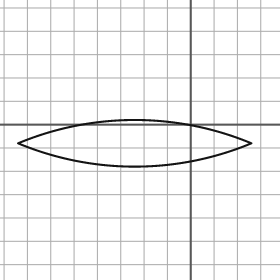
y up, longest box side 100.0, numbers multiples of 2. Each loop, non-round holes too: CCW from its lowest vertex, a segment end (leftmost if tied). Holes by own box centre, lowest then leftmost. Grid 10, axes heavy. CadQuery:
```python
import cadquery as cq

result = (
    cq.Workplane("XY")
    .moveTo(-74.0, -8.0)
    .threePointArc((-24.0, -18.0), (26.0, -8.0))
    .threePointArc((-24.0, 2.0), (-74.0, -8.0))
    .close()
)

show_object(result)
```